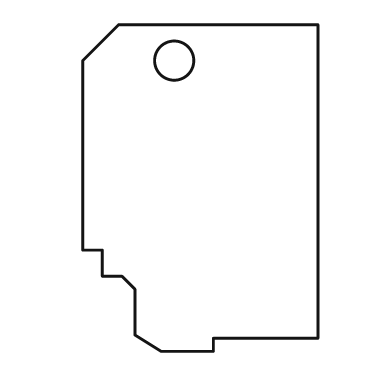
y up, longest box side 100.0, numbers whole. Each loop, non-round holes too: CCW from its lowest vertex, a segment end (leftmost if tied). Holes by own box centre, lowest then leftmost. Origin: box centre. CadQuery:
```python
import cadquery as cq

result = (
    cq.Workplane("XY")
    .moveTo(-12.0, -50.0)
    .lineTo(4.0, -50.0)
    .lineTo(4.0, -46.0)
    .lineTo(36.0, -46.0)
    .lineTo(36.0, 50.0)
    .lineTo(-25.0, 50.0)
    .lineTo(-36.0, 39.0)
    .lineTo(-36.0, -19.0)
    .lineTo(-30.0, -19.0)
    .lineTo(-30.0, -27.0)
    .lineTo(-24.0, -27.0)
    .lineTo(-20.0, -31.0)
    .lineTo(-20.0, -45.0)
    .close()
    .moveTo(-8.0, 39.0)
    .circle(6.0)
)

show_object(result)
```